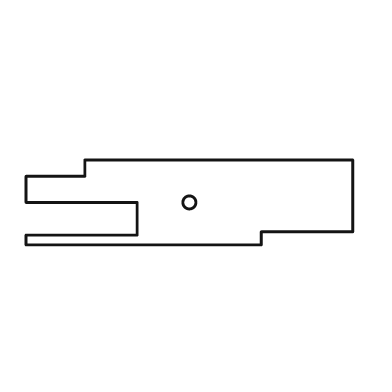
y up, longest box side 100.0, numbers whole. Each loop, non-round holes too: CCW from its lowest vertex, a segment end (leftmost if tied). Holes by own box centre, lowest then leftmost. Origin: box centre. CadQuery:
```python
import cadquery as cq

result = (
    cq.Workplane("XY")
    .moveTo(-50.0, -13.0)
    .lineTo(22.0, -13.0)
    .lineTo(22.0, -9.0)
    .lineTo(50.0, -9.0)
    .lineTo(50.0, 13.0)
    .lineTo(-32.0, 13.0)
    .lineTo(-32.0, 8.0)
    .lineTo(-50.0, 8.0)
    .lineTo(-50.0, 0.0)
    .lineTo(-16.0, 0.0)
    .lineTo(-16.0, -10.0)
    .lineTo(-50.0, -10.0)
    .close()
    .moveTo(0.0, 0.0)
    .circle(2.0)
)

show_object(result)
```